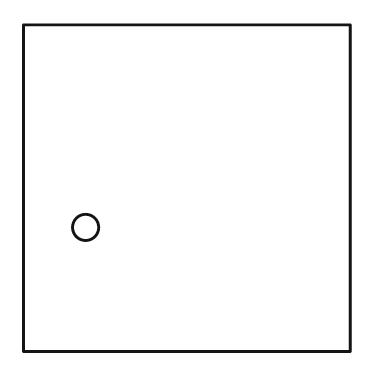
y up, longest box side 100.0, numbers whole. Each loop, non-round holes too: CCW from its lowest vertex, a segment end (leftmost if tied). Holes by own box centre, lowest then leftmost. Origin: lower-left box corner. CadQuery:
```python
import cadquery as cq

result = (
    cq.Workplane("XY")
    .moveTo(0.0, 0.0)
    .lineTo(100.0, 0.0)
    .lineTo(100.0, 100.0)
    .lineTo(0.0, 100.0)
    .close()
    .moveTo(19.0, 38.0)
    .circle(4.0)
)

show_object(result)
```